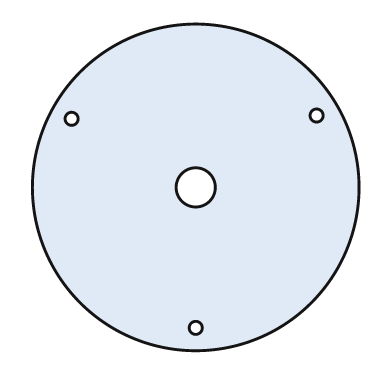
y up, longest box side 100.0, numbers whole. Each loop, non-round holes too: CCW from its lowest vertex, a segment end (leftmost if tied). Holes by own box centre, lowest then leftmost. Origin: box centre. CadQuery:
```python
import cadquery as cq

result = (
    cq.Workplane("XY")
    .moveTo(0.0, 0.0)
    .circle(50.0)
    .moveTo(0.0, -43.0)
    .circle(2.0)
    .moveTo(0.0, 0.0)
    .circle(6.0)
    .moveTo(-38.0, 21.0)
    .circle(2.0)
    .moveTo(37.0, 22.0)
    .circle(2.0)
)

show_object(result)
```